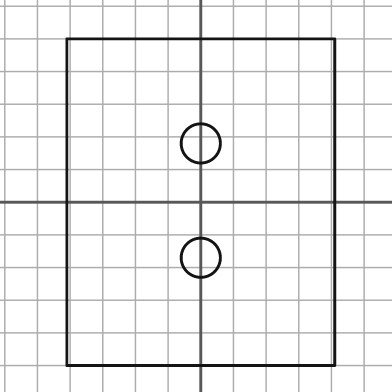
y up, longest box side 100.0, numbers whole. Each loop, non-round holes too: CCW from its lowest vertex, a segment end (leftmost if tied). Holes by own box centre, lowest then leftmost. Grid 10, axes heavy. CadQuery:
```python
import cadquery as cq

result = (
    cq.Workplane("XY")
    .moveTo(-41.0, -50.0)
    .lineTo(41.0, -50.0)
    .lineTo(41.0, 50.0)
    .lineTo(-41.0, 50.0)
    .close()
    .moveTo(0.0, -17.0)
    .circle(6.0)
    .moveTo(0.0, 18.0)
    .circle(6.0)
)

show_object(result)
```